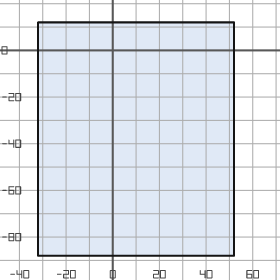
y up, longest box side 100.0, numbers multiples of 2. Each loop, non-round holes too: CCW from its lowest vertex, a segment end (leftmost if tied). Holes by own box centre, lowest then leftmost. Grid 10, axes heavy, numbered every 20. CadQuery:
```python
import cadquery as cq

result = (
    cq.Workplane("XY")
    .moveTo(-32.0, -88.0)
    .lineTo(52.0, -88.0)
    .lineTo(52.0, 12.0)
    .lineTo(-32.0, 12.0)
    .close()
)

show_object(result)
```